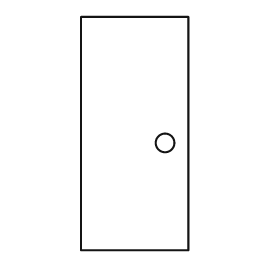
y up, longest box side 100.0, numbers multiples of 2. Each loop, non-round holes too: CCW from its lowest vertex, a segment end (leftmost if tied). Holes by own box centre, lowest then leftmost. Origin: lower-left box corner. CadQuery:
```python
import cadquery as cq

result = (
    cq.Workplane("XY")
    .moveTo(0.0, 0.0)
    .lineTo(46.0, 0.0)
    .lineTo(46.0, 100.0)
    .lineTo(0.0, 100.0)
    .close()
    .moveTo(36.0, 46.0)
    .circle(4.0)
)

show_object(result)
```